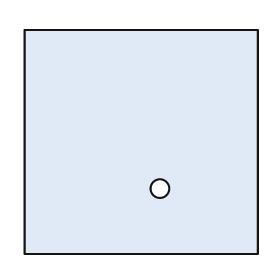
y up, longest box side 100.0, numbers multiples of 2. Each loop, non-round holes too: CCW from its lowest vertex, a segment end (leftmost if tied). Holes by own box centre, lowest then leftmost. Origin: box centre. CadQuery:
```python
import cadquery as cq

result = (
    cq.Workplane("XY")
    .moveTo(-50.0, -48.0)
    .lineTo(50.0, -48.0)
    .lineTo(50.0, 48.0)
    .lineTo(-50.0, 48.0)
    .close()
    .moveTo(8.0, -20.0)
    .circle(4.0)
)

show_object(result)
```